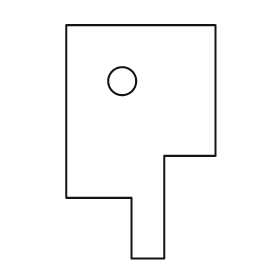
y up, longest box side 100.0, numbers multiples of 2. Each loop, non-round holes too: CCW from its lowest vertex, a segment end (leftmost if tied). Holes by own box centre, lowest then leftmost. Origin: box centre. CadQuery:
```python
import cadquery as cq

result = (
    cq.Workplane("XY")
    .moveTo(-4.0, -50.0)
    .lineTo(10.0, -50.0)
    .lineTo(10.0, -6.0)
    .lineTo(32.0, -6.0)
    .lineTo(32.0, 50.0)
    .lineTo(-32.0, 50.0)
    .lineTo(-32.0, -24.0)
    .lineTo(-4.0, -24.0)
    .close()
    .moveTo(-8.0, 26.0)
    .circle(6.0)
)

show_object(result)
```